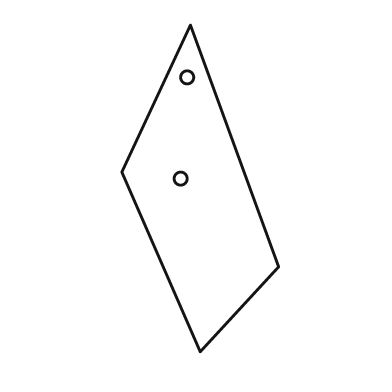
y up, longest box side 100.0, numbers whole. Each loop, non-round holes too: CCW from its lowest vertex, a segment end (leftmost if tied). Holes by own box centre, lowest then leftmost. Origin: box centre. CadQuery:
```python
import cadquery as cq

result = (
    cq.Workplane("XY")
    .moveTo(0.0, -50.0)
    .lineTo(24.0, -24.0)
    .lineTo(-3.0, 50.0)
    .lineTo(-24.0, 5.0)
    .close()
    .moveTo(-6.0, 3.0)
    .circle(2.0)
    .moveTo(-4.0, 34.0)
    .circle(2.0)
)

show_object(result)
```